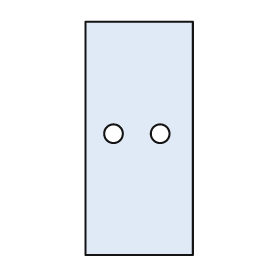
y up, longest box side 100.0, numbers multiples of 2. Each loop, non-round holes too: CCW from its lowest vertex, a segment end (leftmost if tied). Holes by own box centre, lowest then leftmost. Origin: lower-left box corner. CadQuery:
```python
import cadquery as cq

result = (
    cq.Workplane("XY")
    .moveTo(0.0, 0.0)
    .lineTo(46.0, 0.0)
    .lineTo(46.0, 100.0)
    .lineTo(0.0, 100.0)
    .close()
    .moveTo(12.0, 52.0)
    .circle(4.0)
    .moveTo(32.0, 52.0)
    .circle(4.0)
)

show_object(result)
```